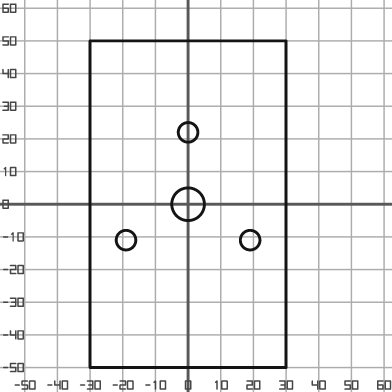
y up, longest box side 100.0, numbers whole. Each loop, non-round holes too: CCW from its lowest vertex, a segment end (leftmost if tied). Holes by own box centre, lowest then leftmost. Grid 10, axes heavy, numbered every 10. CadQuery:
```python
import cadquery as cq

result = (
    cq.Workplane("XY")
    .moveTo(-30.0, -50.0)
    .lineTo(30.0, -50.0)
    .lineTo(30.0, 50.0)
    .lineTo(-30.0, 50.0)
    .close()
    .moveTo(-19.0, -11.0)
    .circle(3.0)
    .moveTo(19.0, -11.0)
    .circle(3.0)
    .moveTo(0.0, 0.0)
    .circle(5.0)
    .moveTo(0.0, 22.0)
    .circle(3.0)
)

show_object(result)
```